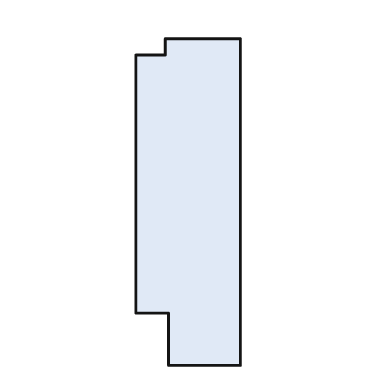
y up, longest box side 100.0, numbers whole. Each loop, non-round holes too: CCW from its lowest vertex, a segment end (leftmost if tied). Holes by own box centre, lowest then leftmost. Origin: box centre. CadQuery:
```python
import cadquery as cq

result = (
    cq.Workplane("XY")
    .moveTo(-6.0, -50.0)
    .lineTo(16.0, -50.0)
    .lineTo(16.0, 50.0)
    .lineTo(-7.0, 50.0)
    .lineTo(-7.0, 45.0)
    .lineTo(-16.0, 45.0)
    .lineTo(-16.0, -34.0)
    .lineTo(-6.0, -34.0)
    .close()
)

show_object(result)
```